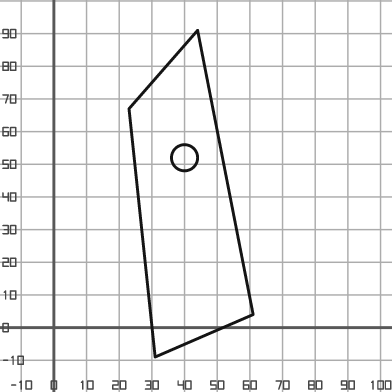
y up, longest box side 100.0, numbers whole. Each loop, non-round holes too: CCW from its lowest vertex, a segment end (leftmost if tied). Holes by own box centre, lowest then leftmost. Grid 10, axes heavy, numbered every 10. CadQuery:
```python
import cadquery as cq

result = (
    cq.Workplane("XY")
    .moveTo(31.0, -9.0)
    .lineTo(61.0, 4.0)
    .lineTo(44.0, 91.0)
    .lineTo(23.0, 67.0)
    .close()
    .moveTo(40.0, 52.0)
    .circle(4.0)
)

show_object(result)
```